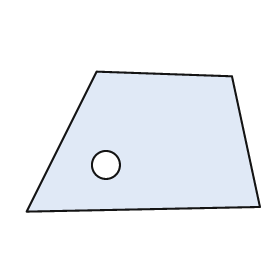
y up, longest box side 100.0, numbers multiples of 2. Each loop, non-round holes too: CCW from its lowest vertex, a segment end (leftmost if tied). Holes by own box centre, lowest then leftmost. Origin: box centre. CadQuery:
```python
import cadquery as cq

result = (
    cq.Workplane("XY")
    .moveTo(-50.0, -30.0)
    .lineTo(50.0, -28.0)
    .lineTo(38.0, 28.0)
    .lineTo(-20.0, 30.0)
    .close()
    .moveTo(-16.0, -10.0)
    .circle(6.0)
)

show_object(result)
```